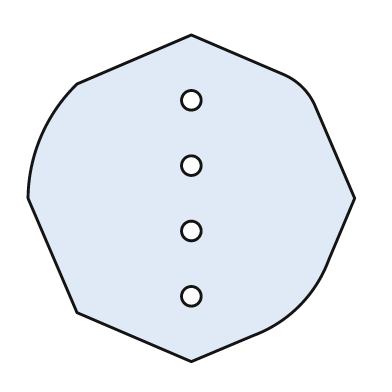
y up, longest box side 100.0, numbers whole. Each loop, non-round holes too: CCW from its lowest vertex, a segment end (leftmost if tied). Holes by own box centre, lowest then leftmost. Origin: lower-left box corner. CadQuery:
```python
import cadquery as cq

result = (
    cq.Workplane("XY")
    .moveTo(50.0, 0.0)
    .lineTo(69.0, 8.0)
    .threePointArc((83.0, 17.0), (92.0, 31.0))
    .lineTo(100.0, 50.0)
    .lineTo(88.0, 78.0)
    .threePointArc((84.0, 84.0), (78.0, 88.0))
    .lineTo(50.0, 100.0)
    .lineTo(15.0, 85.0)
    .threePointArc((4.0, 69.0), (0.0, 50.0))
    .lineTo(15.0, 15.0)
    .close()
    .moveTo(50.0, 20.0)
    .circle(3.0)
    .moveTo(50.0, 40.0)
    .circle(3.0)
    .moveTo(50.0, 60.0)
    .circle(3.0)
    .moveTo(50.0, 80.0)
    .circle(3.0)
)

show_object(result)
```